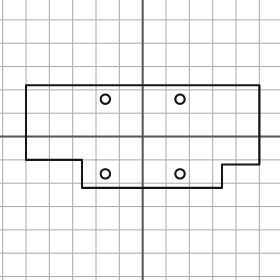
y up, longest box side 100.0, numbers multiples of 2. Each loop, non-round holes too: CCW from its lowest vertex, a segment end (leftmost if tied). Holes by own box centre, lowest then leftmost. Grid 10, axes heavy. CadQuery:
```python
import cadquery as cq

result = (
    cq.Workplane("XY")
    .moveTo(-26.0, -22.0)
    .lineTo(34.0, -22.0)
    .lineTo(34.0, -12.0)
    .lineTo(50.0, -12.0)
    .lineTo(50.0, 22.0)
    .lineTo(-50.0, 22.0)
    .lineTo(-50.0, -10.0)
    .lineTo(-26.0, -10.0)
    .close()
    .moveTo(-16.0, -16.0)
    .circle(2.0)
    .moveTo(16.0, -16.0)
    .circle(2.0)
    .moveTo(-16.0, 16.0)
    .circle(2.0)
    .moveTo(16.0, 16.0)
    .circle(2.0)
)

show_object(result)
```